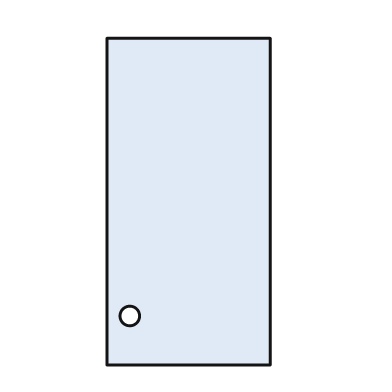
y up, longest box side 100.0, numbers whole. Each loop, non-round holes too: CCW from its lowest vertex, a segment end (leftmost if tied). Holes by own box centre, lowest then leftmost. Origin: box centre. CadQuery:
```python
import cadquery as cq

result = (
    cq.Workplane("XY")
    .moveTo(-25.0, -50.0)
    .lineTo(25.0, -50.0)
    .lineTo(25.0, 50.0)
    .lineTo(-25.0, 50.0)
    .close()
    .moveTo(-18.0, -35.0)
    .circle(3.0)
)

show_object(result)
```